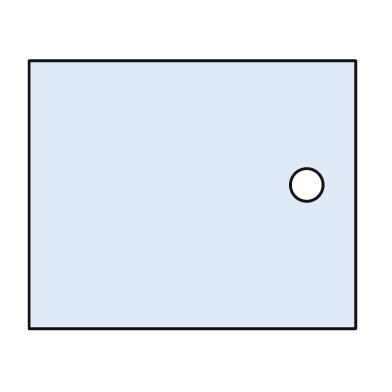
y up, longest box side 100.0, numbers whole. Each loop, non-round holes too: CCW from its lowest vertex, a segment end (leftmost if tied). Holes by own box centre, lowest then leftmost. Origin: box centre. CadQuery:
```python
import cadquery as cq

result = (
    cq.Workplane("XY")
    .moveTo(-50.0, -41.0)
    .lineTo(50.0, -41.0)
    .lineTo(50.0, 41.0)
    .lineTo(-50.0, 41.0)
    .close()
    .moveTo(35.0, 3.0)
    .circle(5.0)
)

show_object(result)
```